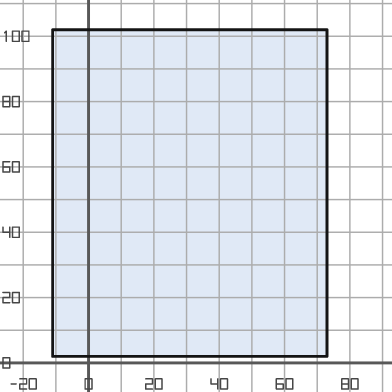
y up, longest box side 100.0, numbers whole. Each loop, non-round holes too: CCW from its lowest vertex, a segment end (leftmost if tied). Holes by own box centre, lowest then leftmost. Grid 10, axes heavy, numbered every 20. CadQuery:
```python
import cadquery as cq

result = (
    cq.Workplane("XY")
    .moveTo(-11.0, 2.0)
    .lineTo(73.0, 2.0)
    .lineTo(73.0, 102.0)
    .lineTo(-11.0, 102.0)
    .close()
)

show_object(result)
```